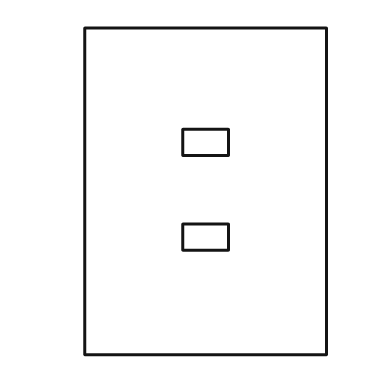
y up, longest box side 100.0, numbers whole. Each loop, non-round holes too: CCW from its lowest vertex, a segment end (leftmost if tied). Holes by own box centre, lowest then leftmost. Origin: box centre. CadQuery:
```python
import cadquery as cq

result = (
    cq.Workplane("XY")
    .moveTo(-37.0, -50.0)
    .lineTo(37.0, -50.0)
    .lineTo(37.0, 50.0)
    .lineTo(-37.0, 50.0)
    .close()
    .moveTo(-7.0, -18.0)
    .lineTo(7.0, -18.0)
    .lineTo(7.0, -10.0)
    .lineTo(-7.0, -10.0)
    .close()
    .moveTo(-7.0, 11.0)
    .lineTo(7.0, 11.0)
    .lineTo(7.0, 19.0)
    .lineTo(-7.0, 19.0)
    .close()
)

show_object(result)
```